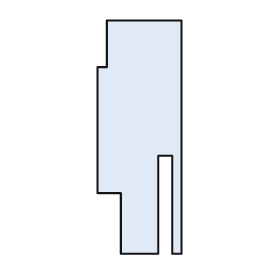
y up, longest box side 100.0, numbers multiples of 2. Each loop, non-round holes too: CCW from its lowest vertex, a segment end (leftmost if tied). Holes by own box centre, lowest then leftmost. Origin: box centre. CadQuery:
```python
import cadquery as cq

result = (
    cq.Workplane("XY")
    .moveTo(-8.0, -50.0)
    .lineTo(8.0, -50.0)
    .lineTo(8.0, -8.0)
    .lineTo(14.0, -8.0)
    .lineTo(14.0, -50.0)
    .lineTo(18.0, -50.0)
    .lineTo(18.0, 50.0)
    .lineTo(-14.0, 50.0)
    .lineTo(-14.0, 30.0)
    .lineTo(-18.0, 30.0)
    .lineTo(-18.0, -24.0)
    .lineTo(-8.0, -24.0)
    .close()
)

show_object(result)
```